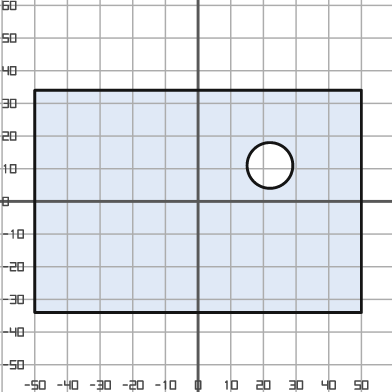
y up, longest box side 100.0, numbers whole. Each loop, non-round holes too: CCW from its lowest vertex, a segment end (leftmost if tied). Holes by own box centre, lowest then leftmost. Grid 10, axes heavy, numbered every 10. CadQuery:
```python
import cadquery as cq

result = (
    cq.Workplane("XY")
    .moveTo(-50.0, -34.0)
    .lineTo(50.0, -34.0)
    .lineTo(50.0, 34.0)
    .lineTo(-50.0, 34.0)
    .close()
    .moveTo(22.0, 11.0)
    .circle(7.0)
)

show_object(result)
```